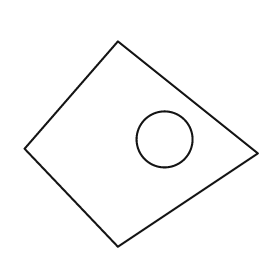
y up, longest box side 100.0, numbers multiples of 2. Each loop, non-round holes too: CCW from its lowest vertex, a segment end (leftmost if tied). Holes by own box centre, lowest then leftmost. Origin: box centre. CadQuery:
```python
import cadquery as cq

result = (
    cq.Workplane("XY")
    .moveTo(-10.0, -44.0)
    .lineTo(50.0, -4.0)
    .lineTo(-10.0, 44.0)
    .lineTo(-50.0, -2.0)
    .close()
    .moveTo(10.0, 2.0)
    .circle(12.0)
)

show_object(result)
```